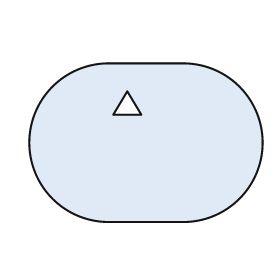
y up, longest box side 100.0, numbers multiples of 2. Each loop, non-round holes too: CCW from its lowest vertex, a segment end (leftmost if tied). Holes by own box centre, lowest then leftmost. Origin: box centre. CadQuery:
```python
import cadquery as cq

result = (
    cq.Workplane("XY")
    .moveTo(-16.0, -34.0)
    .lineTo(16.0, -34.0)
    .threePointArc((50.0, 0.0), (16.0, 34.0))
    .lineTo(-16.0, 34.0)
    .threePointArc((-50.0, 0.0), (-16.0, -34.0))
    .close()
    .moveTo(-14.0, 12.0)
    .lineTo(-2.0, 12.0)
    .lineTo(-8.0, 22.0)
    .close()
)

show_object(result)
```